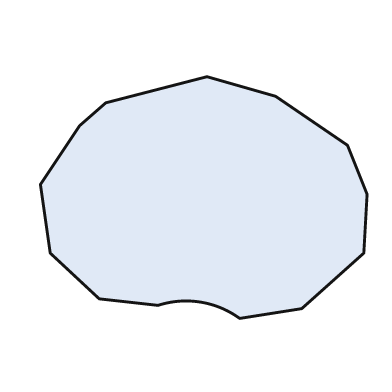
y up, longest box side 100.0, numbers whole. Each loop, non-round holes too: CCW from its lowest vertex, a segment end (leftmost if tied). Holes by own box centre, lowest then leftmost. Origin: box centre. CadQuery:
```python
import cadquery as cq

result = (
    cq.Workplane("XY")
    .moveTo(11.0, -37.0)
    .lineTo(30.0, -34.0)
    .lineTo(49.0, -17.0)
    .lineTo(50.0, 1.0)
    .lineTo(44.0, 16.0)
    .lineTo(22.0, 31.0)
    .lineTo(1.0, 37.0)
    .lineTo(-30.0, 29.0)
    .lineTo(-38.0, 22.0)
    .lineTo(-50.0, 4.0)
    .lineTo(-47.0, -17.0)
    .lineTo(-32.0, -31.0)
    .lineTo(-14.0, -33.0)
    .threePointArc((-1.0, -32.0), (11.0, -37.0))
    .close()
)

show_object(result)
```